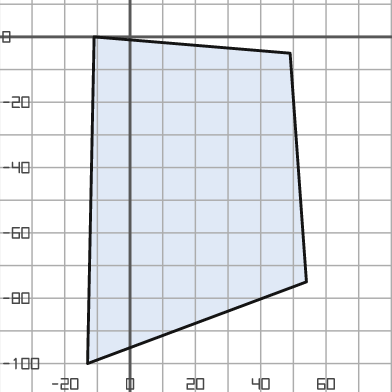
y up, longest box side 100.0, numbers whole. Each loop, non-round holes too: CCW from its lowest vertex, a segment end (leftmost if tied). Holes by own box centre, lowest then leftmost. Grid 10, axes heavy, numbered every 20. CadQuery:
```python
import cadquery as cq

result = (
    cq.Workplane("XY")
    .moveTo(-13.0, -100.0)
    .lineTo(54.0, -75.0)
    .lineTo(49.0, -5.0)
    .lineTo(-11.0, 0.0)
    .close()
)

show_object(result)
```